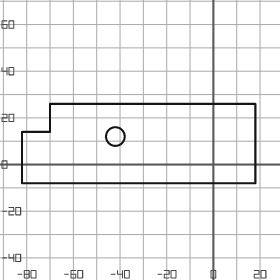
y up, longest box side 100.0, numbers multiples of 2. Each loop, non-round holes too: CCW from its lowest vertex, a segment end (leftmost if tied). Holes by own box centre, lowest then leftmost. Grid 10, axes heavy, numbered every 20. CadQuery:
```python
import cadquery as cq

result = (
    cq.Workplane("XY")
    .moveTo(-82.0, -8.0)
    .lineTo(18.0, -8.0)
    .lineTo(18.0, 26.0)
    .lineTo(-70.0, 26.0)
    .lineTo(-70.0, 14.0)
    .lineTo(-82.0, 14.0)
    .close()
    .moveTo(-42.0, 12.0)
    .circle(4.0)
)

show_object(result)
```